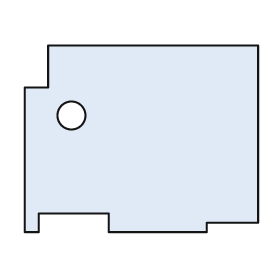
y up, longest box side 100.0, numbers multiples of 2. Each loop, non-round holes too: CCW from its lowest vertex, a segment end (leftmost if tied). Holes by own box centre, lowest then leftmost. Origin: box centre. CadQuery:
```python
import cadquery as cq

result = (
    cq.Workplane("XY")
    .moveTo(-50.0, -40.0)
    .lineTo(-44.0, -40.0)
    .lineTo(-44.0, -32.0)
    .lineTo(-14.0, -32.0)
    .lineTo(-14.0, -40.0)
    .lineTo(28.0, -40.0)
    .lineTo(28.0, -36.0)
    .lineTo(50.0, -36.0)
    .lineTo(50.0, 40.0)
    .lineTo(-40.0, 40.0)
    .lineTo(-40.0, 22.0)
    .lineTo(-50.0, 22.0)
    .close()
    .moveTo(-30.0, 10.0)
    .circle(6.0)
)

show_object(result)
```